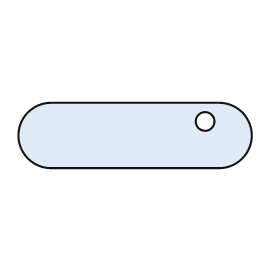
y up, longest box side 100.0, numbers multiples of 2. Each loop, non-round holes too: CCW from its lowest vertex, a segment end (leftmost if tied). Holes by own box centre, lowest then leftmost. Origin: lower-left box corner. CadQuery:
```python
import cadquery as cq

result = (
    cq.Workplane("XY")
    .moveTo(14.0, 0.0)
    .lineTo(86.0, 0.0)
    .threePointArc((100.0, 14.0), (86.0, 28.0))
    .lineTo(14.0, 28.0)
    .threePointArc((0.0, 14.0), (14.0, 0.0))
    .close()
    .moveTo(80.0, 20.0)
    .circle(4.0)
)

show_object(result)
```